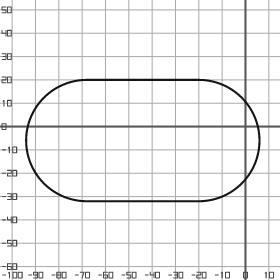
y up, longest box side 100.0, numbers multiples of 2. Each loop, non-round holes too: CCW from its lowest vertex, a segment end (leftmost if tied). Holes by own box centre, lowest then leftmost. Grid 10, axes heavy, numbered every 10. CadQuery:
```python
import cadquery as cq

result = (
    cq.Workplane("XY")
    .moveTo(-68.0, -32.0)
    .lineTo(-20.0, -32.0)
    .threePointArc((6.0, -6.0), (-20.0, 20.0))
    .lineTo(-68.0, 20.0)
    .threePointArc((-94.0, -6.0), (-68.0, -32.0))
    .close()
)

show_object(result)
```